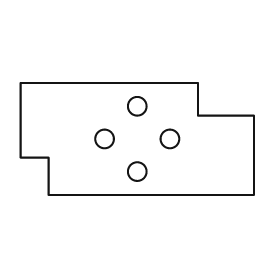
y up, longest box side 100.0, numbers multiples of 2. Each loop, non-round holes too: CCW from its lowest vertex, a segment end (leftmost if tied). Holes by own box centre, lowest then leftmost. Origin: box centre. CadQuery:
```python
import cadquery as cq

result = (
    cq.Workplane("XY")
    .moveTo(-38.0, -24.0)
    .lineTo(50.0, -24.0)
    .lineTo(50.0, 10.0)
    .lineTo(26.0, 10.0)
    .lineTo(26.0, 24.0)
    .lineTo(-50.0, 24.0)
    .lineTo(-50.0, -8.0)
    .lineTo(-38.0, -8.0)
    .close()
    .moveTo(0.0, -14.0)
    .circle(4.0)
    .moveTo(-14.0, 0.0)
    .circle(4.0)
    .moveTo(14.0, 0.0)
    .circle(4.0)
    .moveTo(0.0, 14.0)
    .circle(4.0)
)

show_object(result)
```